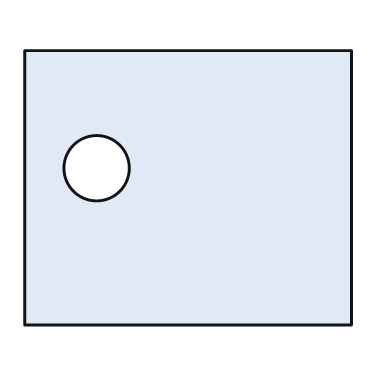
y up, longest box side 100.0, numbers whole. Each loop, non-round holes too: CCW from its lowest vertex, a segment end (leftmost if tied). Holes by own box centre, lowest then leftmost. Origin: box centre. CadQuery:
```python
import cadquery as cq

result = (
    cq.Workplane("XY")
    .moveTo(-50.0, -42.0)
    .lineTo(50.0, -42.0)
    .lineTo(50.0, 42.0)
    .lineTo(-50.0, 42.0)
    .close()
    .moveTo(-28.0, 6.0)
    .circle(10.0)
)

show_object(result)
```